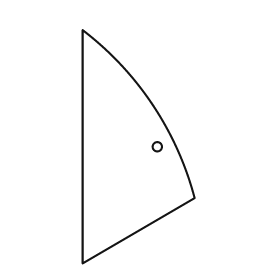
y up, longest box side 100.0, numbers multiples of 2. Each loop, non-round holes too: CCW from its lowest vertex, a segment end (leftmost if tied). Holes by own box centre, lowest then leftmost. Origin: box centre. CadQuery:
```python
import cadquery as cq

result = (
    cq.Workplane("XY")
    .moveTo(-24.0, -50.0)
    .lineTo(24.0, -22.0)
    .threePointArc((6.0, 18.0), (-24.0, 50.0))
    .close()
    .moveTo(8.0, 0.0)
    .circle(2.0)
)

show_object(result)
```